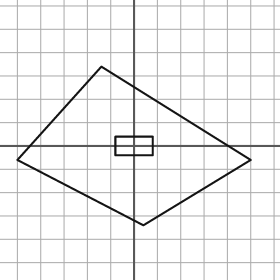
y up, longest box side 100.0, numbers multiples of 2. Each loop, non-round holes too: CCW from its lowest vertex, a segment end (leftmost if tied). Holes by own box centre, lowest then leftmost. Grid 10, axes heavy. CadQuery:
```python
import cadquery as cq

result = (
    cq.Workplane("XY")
    .moveTo(4.0, -34.0)
    .lineTo(50.0, -6.0)
    .lineTo(-14.0, 34.0)
    .lineTo(-50.0, -6.0)
    .close()
    .moveTo(-8.0, -4.0)
    .lineTo(8.0, -4.0)
    .lineTo(8.0, 4.0)
    .lineTo(-8.0, 4.0)
    .close()
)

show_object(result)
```